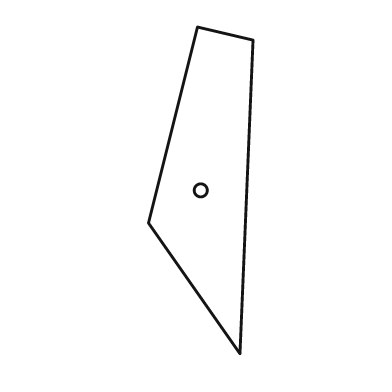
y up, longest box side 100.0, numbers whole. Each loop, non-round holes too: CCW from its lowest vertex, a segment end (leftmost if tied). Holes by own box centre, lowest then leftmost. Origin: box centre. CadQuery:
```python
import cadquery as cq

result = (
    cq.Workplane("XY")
    .moveTo(12.0, -50.0)
    .lineTo(16.0, 46.0)
    .lineTo(-1.0, 50.0)
    .lineTo(-16.0, -10.0)
    .close()
    .moveTo(0.0, 0.0)
    .circle(2.0)
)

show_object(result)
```